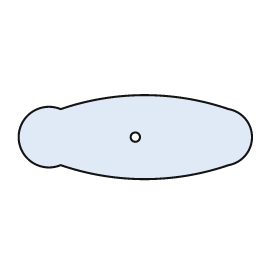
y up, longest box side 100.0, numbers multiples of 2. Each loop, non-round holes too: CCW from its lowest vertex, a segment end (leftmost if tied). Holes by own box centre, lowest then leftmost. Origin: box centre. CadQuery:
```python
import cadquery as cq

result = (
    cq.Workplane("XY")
    .moveTo(-32.0, -12.0)
    .threePointArc((4.0, -18.0), (40.0, -12.0))
    .threePointArc((50.0, 0.0), (40.0, 12.0))
    .threePointArc((4.0, 18.0), (-32.0, 12.0))
    .threePointArc((-50.0, 0.0), (-32.0, -12.0))
    .close()
    .moveTo(0.0, 0.0)
    .circle(2.0)
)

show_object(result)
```